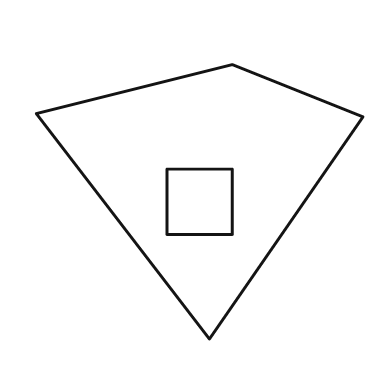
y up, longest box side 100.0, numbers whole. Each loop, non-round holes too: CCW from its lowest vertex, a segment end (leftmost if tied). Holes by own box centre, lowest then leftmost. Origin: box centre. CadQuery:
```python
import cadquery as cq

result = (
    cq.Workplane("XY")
    .moveTo(3.0, -42.0)
    .lineTo(50.0, 26.0)
    .lineTo(10.0, 42.0)
    .lineTo(-50.0, 27.0)
    .close()
    .moveTo(-10.0, -10.0)
    .lineTo(10.0, -10.0)
    .lineTo(10.0, 10.0)
    .lineTo(-10.0, 10.0)
    .close()
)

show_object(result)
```